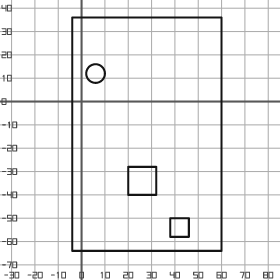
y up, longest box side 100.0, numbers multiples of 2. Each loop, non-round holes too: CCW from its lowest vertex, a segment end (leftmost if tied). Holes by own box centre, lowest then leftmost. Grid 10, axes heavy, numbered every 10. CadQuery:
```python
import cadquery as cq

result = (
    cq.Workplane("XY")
    .moveTo(-4.0, -64.0)
    .lineTo(60.0, -64.0)
    .lineTo(60.0, 36.0)
    .lineTo(-4.0, 36.0)
    .close()
    .moveTo(38.0, -58.0)
    .lineTo(46.0, -58.0)
    .lineTo(46.0, -50.0)
    .lineTo(38.0, -50.0)
    .close()
    .moveTo(20.0, -40.0)
    .lineTo(32.0, -40.0)
    .lineTo(32.0, -28.0)
    .lineTo(20.0, -28.0)
    .close()
    .moveTo(6.0, 12.0)
    .circle(4.0)
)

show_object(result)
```